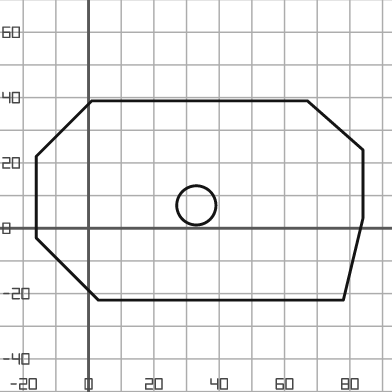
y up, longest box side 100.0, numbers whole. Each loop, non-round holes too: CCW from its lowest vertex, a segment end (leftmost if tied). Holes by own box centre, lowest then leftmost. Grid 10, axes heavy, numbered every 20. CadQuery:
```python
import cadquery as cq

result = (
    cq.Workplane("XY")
    .moveTo(3.0, -22.0)
    .lineTo(78.0, -22.0)
    .lineTo(84.0, 3.0)
    .lineTo(84.0, 24.0)
    .lineTo(67.0, 39.0)
    .lineTo(1.0, 39.0)
    .lineTo(-16.0, 22.0)
    .lineTo(-16.0, -3.0)
    .close()
    .moveTo(33.0, 7.0)
    .circle(6.0)
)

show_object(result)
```